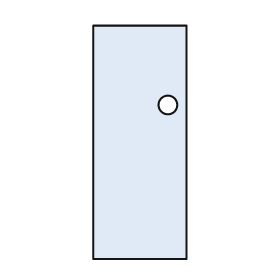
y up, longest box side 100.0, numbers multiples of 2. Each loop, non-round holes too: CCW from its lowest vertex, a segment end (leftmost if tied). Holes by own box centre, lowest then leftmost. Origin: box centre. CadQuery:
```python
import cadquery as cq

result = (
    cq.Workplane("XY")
    .moveTo(-20.0, -50.0)
    .lineTo(20.0, -50.0)
    .lineTo(20.0, 50.0)
    .lineTo(-20.0, 50.0)
    .close()
    .moveTo(12.0, 16.0)
    .circle(4.0)
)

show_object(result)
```